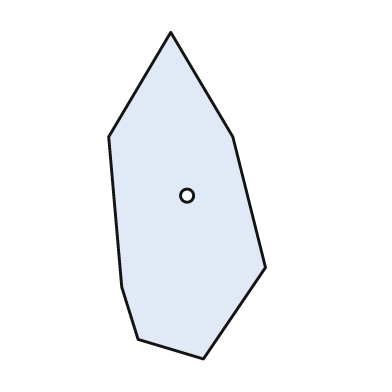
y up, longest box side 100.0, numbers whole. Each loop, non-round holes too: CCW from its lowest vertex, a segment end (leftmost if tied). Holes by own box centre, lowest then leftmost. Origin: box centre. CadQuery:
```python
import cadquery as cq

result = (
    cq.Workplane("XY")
    .moveTo(5.0, -50.0)
    .lineTo(24.0, -22.0)
    .lineTo(14.0, 18.0)
    .lineTo(-5.0, 50.0)
    .lineTo(-24.0, 18.0)
    .lineTo(-20.0, -28.0)
    .lineTo(-15.0, -44.0)
    .close()
    .moveTo(0.0, 0.0)
    .circle(2.0)
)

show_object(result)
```